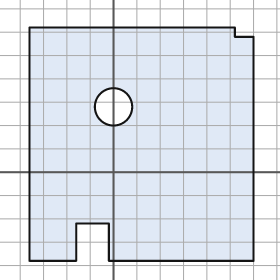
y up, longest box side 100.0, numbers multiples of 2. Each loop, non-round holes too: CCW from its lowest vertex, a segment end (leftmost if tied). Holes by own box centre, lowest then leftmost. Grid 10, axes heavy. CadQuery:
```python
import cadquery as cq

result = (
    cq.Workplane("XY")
    .moveTo(-36.0, -38.0)
    .lineTo(-16.0, -38.0)
    .lineTo(-16.0, -22.0)
    .lineTo(-2.0, -22.0)
    .lineTo(-2.0, -38.0)
    .lineTo(60.0, -38.0)
    .lineTo(60.0, 58.0)
    .lineTo(52.0, 58.0)
    .lineTo(52.0, 62.0)
    .lineTo(-36.0, 62.0)
    .close()
    .moveTo(0.0, 28.0)
    .circle(8.0)
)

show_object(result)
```